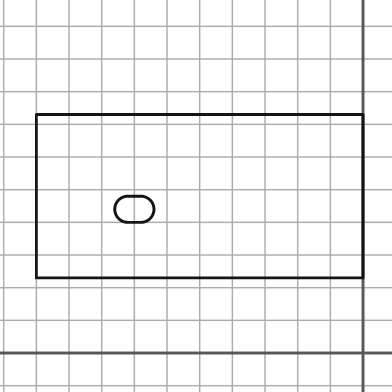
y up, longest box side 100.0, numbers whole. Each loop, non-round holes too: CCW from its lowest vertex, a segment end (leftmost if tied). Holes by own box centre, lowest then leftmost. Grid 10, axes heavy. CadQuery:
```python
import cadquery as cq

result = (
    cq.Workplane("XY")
    .moveTo(-100.0, 23.0)
    .lineTo(0.0, 23.0)
    .lineTo(0.0, 73.0)
    .lineTo(-100.0, 73.0)
    .close()
    .moveTo(-72.0, 40.0)
    .lineTo(-68.0, 40.0)
    .threePointArc((-64.0, 44.0), (-68.0, 48.0))
    .lineTo(-72.0, 48.0)
    .threePointArc((-76.0, 44.0), (-72.0, 40.0))
    .close()
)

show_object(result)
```